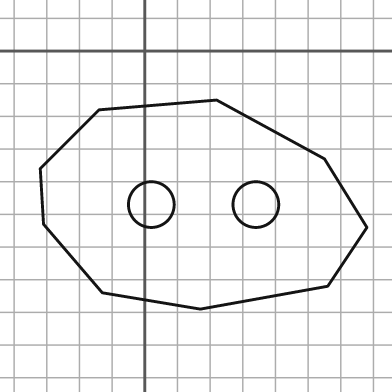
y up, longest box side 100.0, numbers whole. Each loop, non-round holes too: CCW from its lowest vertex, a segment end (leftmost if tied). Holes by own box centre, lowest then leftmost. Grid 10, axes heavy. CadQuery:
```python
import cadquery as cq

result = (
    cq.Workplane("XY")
    .moveTo(17.0, -79.0)
    .lineTo(56.0, -72.0)
    .lineTo(68.0, -54.0)
    .lineTo(55.0, -33.0)
    .lineTo(22.0, -15.0)
    .lineTo(-14.0, -18.0)
    .lineTo(-32.0, -36.0)
    .lineTo(-31.0, -53.0)
    .lineTo(-13.0, -74.0)
    .close()
    .moveTo(2.0, -47.0)
    .circle(7.0)
    .moveTo(34.0, -47.0)
    .circle(7.0)
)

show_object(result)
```